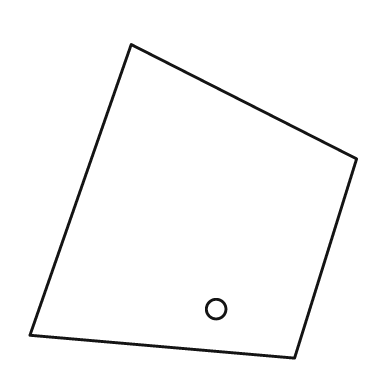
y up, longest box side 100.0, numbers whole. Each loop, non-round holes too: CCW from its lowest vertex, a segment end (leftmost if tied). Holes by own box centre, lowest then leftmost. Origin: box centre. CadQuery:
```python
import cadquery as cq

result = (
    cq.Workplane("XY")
    .moveTo(31.0, -48.0)
    .lineTo(50.0, 13.0)
    .lineTo(-19.0, 48.0)
    .lineTo(-50.0, -41.0)
    .close()
    .moveTo(7.0, -33.0)
    .circle(3.0)
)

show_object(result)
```